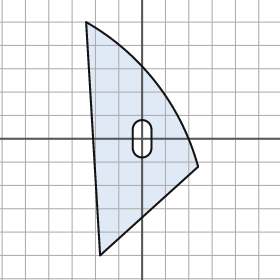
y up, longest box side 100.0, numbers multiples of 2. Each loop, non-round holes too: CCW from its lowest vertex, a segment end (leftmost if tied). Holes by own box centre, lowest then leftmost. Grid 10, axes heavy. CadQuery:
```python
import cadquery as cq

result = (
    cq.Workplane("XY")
    .moveTo(-18.0, -50.0)
    .lineTo(24.0, -12.0)
    .threePointArc((6.0, 24.0), (-24.0, 50.0))
    .close()
    .moveTo(-4.0, -4.0)
    .threePointArc((0.0, -8.0), (4.0, -4.0))
    .lineTo(4.0, 4.0)
    .threePointArc((0.0, 8.0), (-4.0, 4.0))
    .close()
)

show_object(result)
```